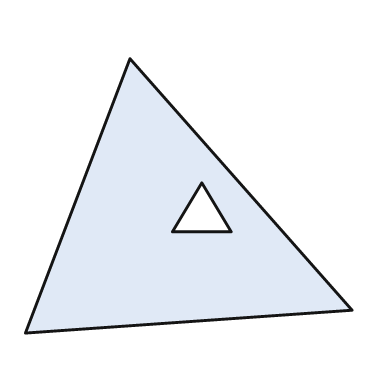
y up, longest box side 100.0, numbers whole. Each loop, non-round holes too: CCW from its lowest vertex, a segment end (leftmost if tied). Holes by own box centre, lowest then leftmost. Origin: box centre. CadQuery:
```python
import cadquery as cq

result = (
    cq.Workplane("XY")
    .moveTo(-50.0, -42.0)
    .lineTo(50.0, -35.0)
    .lineTo(-18.0, 42.0)
    .close()
    .moveTo(-5.0, -11.0)
    .lineTo(13.0, -11.0)
    .lineTo(4.0, 4.0)
    .close()
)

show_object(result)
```